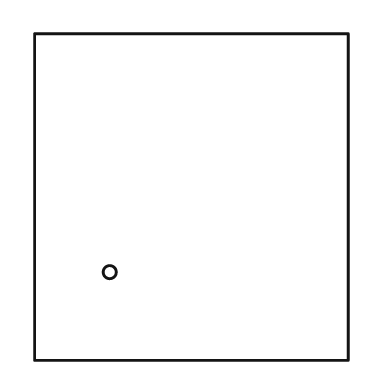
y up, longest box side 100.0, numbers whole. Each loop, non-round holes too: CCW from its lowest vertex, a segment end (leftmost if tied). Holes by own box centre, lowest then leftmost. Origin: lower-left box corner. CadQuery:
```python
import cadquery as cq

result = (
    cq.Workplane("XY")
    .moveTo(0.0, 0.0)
    .lineTo(96.0, 0.0)
    .lineTo(96.0, 100.0)
    .lineTo(0.0, 100.0)
    .close()
    .moveTo(23.0, 27.0)
    .circle(2.0)
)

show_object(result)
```